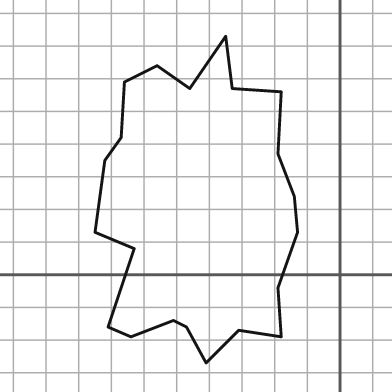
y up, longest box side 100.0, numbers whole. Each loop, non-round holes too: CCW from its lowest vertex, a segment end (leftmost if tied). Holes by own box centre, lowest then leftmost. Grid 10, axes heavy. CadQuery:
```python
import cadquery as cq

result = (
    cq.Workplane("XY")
    .moveTo(-41.0, -27.0)
    .lineTo(-31.0, -17.0)
    .lineTo(-18.0, -19.0)
    .lineTo(-19.0, -4.0)
    .lineTo(-13.0, 13.0)
    .lineTo(-14.0, 24.0)
    .lineTo(-19.0, 37.0)
    .lineTo(-18.0, 56.0)
    .lineTo(-33.0, 57.0)
    .lineTo(-35.0, 73.0)
    .lineTo(-46.0, 57.0)
    .lineTo(-56.0, 64.0)
    .lineTo(-66.0, 59.0)
    .lineTo(-67.0, 42.0)
    .lineTo(-72.0, 35.0)
    .lineTo(-75.0, 13.0)
    .lineTo(-63.0, 8.0)
    .lineTo(-71.0, -16.0)
    .lineTo(-64.0, -19.0)
    .lineTo(-51.0, -14.0)
    .lineTo(-47.0, -16.0)
    .close()
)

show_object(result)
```